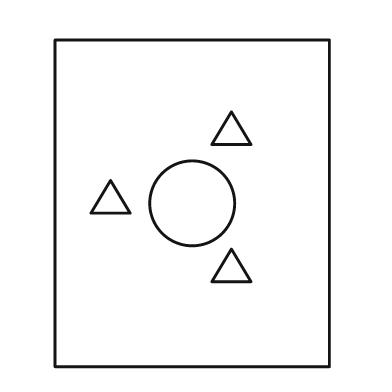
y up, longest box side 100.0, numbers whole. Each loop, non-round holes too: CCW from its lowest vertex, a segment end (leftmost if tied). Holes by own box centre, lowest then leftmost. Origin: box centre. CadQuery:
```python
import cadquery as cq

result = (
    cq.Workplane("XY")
    .moveTo(-42.0, -50.0)
    .lineTo(42.0, -50.0)
    .lineTo(42.0, 50.0)
    .lineTo(-42.0, 50.0)
    .close()
    .moveTo(6.0, -24.0)
    .lineTo(18.0, -24.0)
    .lineTo(12.0, -14.0)
    .close()
    .moveTo(0.0, 0.0)
    .circle(13.0)
    .moveTo(-31.0, -3.0)
    .lineTo(-19.0, -3.0)
    .lineTo(-25.0, 7.0)
    .close()
    .moveTo(6.0, 18.0)
    .lineTo(18.0, 18.0)
    .lineTo(12.0, 28.0)
    .close()
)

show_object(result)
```